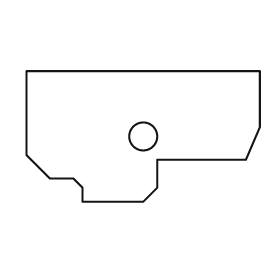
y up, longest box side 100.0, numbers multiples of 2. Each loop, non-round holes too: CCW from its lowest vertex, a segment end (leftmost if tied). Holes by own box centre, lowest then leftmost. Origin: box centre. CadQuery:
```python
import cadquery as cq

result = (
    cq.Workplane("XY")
    .moveTo(-26.0, -28.0)
    .lineTo(0.0, -28.0)
    .lineTo(6.0, -22.0)
    .lineTo(6.0, -10.0)
    .lineTo(44.0, -10.0)
    .lineTo(50.0, 4.0)
    .lineTo(50.0, 28.0)
    .lineTo(-50.0, 28.0)
    .lineTo(-50.0, -8.0)
    .lineTo(-40.0, -18.0)
    .lineTo(-30.0, -18.0)
    .lineTo(-26.0, -22.0)
    .close()
    .moveTo(0.0, 0.0)
    .circle(6.0)
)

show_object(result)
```